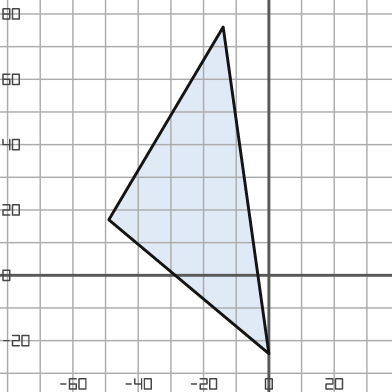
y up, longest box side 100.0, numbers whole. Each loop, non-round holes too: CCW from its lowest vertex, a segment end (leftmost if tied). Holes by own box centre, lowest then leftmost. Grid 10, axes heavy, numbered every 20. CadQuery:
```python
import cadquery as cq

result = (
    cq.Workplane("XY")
    .moveTo(0.0, -24.0)
    .lineTo(-14.0, 76.0)
    .lineTo(-49.0, 17.0)
    .close()
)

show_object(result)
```